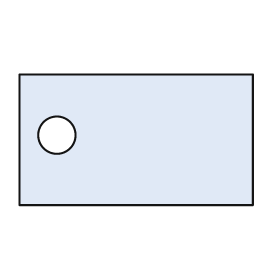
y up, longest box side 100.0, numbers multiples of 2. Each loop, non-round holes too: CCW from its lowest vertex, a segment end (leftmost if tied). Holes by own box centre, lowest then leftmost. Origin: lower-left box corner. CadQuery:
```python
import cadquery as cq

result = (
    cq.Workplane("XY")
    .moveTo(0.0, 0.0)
    .lineTo(100.0, 0.0)
    .lineTo(100.0, 56.0)
    .lineTo(0.0, 56.0)
    .close()
    .moveTo(16.0, 30.0)
    .circle(8.0)
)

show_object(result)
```